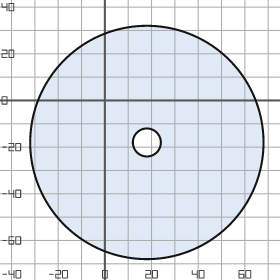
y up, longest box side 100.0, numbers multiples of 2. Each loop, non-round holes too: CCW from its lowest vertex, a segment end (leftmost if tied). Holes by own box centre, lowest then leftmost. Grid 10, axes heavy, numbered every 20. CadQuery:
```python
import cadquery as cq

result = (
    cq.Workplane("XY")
    .moveTo(18.0, -18.0)
    .circle(50.0)
    .moveTo(18.0, -18.0)
    .circle(6.0)
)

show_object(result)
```